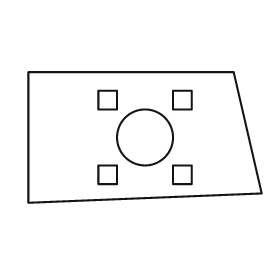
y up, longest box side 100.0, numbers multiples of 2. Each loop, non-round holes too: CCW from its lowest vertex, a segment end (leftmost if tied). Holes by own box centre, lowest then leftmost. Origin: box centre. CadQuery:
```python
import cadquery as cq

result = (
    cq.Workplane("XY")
    .moveTo(-50.0, -28.0)
    .lineTo(50.0, -24.0)
    .lineTo(38.0, 28.0)
    .lineTo(-50.0, 28.0)
    .close()
    .moveTo(-20.0, -20.0)
    .lineTo(-12.0, -20.0)
    .lineTo(-12.0, -12.0)
    .lineTo(-20.0, -12.0)
    .close()
    .moveTo(12.0, -20.0)
    .lineTo(20.0, -20.0)
    .lineTo(20.0, -12.0)
    .lineTo(12.0, -12.0)
    .close()
    .moveTo(0.0, 0.0)
    .circle(12.0)
    .moveTo(-20.0, 12.0)
    .lineTo(-12.0, 12.0)
    .lineTo(-12.0, 20.0)
    .lineTo(-20.0, 20.0)
    .close()
    .moveTo(12.0, 12.0)
    .lineTo(20.0, 12.0)
    .lineTo(20.0, 20.0)
    .lineTo(12.0, 20.0)
    .close()
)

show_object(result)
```